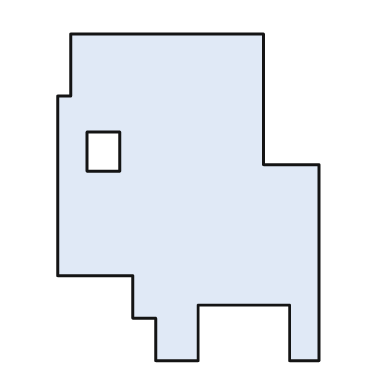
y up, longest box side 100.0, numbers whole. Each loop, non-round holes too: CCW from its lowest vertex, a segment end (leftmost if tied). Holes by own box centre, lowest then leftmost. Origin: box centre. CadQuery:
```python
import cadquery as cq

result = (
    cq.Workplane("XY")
    .moveTo(-10.0, -50.0)
    .lineTo(3.0, -50.0)
    .lineTo(3.0, -33.0)
    .lineTo(31.0, -33.0)
    .lineTo(31.0, -50.0)
    .lineTo(40.0, -50.0)
    .lineTo(40.0, 10.0)
    .lineTo(23.0, 10.0)
    .lineTo(23.0, 50.0)
    .lineTo(-36.0, 50.0)
    .lineTo(-36.0, 31.0)
    .lineTo(-40.0, 31.0)
    .lineTo(-40.0, -24.0)
    .lineTo(-17.0, -24.0)
    .lineTo(-17.0, -37.0)
    .lineTo(-10.0, -37.0)
    .close()
    .moveTo(-31.0, 8.0)
    .lineTo(-21.0, 8.0)
    .lineTo(-21.0, 20.0)
    .lineTo(-31.0, 20.0)
    .close()
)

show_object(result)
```